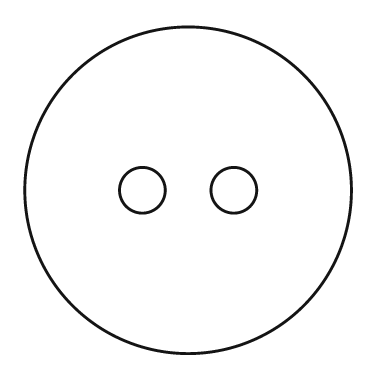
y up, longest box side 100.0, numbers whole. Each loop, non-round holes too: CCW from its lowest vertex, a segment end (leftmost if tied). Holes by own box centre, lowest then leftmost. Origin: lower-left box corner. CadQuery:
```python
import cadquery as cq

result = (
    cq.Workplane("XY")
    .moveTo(50.0, 50.0)
    .circle(50.0)
    .moveTo(36.0, 50.0)
    .circle(7.0)
    .moveTo(64.0, 50.0)
    .circle(7.0)
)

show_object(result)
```